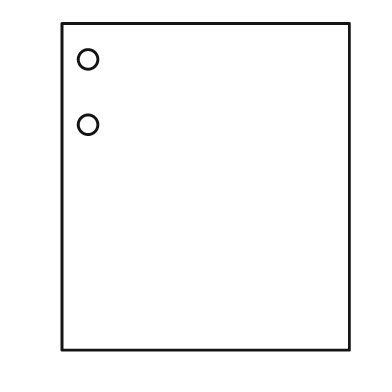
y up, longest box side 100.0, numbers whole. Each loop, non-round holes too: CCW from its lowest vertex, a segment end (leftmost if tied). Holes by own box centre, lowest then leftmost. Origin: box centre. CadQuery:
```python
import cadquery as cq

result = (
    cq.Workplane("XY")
    .moveTo(-44.0, -50.0)
    .lineTo(44.0, -50.0)
    .lineTo(44.0, 50.0)
    .lineTo(-44.0, 50.0)
    .close()
    .moveTo(-36.0, 19.0)
    .circle(3.0)
    .moveTo(-36.0, 39.0)
    .circle(3.0)
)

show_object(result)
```